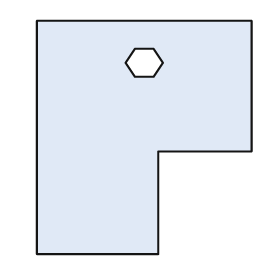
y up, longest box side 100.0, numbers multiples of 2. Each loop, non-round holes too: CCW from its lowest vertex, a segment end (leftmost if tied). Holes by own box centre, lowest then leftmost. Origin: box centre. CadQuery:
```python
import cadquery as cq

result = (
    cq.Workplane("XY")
    .moveTo(-46.0, -50.0)
    .lineTo(6.0, -50.0)
    .lineTo(6.0, -6.0)
    .lineTo(46.0, -6.0)
    .lineTo(46.0, 50.0)
    .lineTo(-46.0, 50.0)
    .close()
    .moveTo(-4.0, 26.0)
    .lineTo(4.0, 26.0)
    .lineTo(8.0, 32.0)
    .lineTo(4.0, 38.0)
    .lineTo(-4.0, 38.0)
    .lineTo(-8.0, 32.0)
    .close()
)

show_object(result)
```